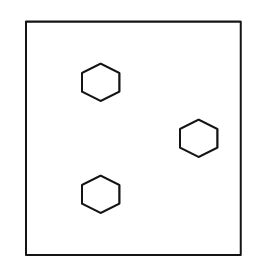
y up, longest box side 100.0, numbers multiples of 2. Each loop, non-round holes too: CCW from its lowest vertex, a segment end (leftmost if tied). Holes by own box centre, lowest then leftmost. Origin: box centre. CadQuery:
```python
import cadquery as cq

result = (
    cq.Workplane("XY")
    .moveTo(-46.0, -50.0)
    .lineTo(46.0, -50.0)
    .lineTo(46.0, 50.0)
    .lineTo(-46.0, 50.0)
    .close()
    .moveTo(-14.0, -32.0)
    .lineTo(-6.0, -28.0)
    .lineTo(-6.0, -20.0)
    .lineTo(-14.0, -16.0)
    .lineTo(-22.0, -20.0)
    .lineTo(-22.0, -28.0)
    .close()
    .moveTo(28.0, -8.0)
    .lineTo(36.0, -4.0)
    .lineTo(36.0, 4.0)
    .lineTo(28.0, 8.0)
    .lineTo(20.0, 4.0)
    .lineTo(20.0, -4.0)
    .close()
    .moveTo(-14.0, 16.0)
    .lineTo(-6.0, 20.0)
    .lineTo(-6.0, 28.0)
    .lineTo(-14.0, 32.0)
    .lineTo(-22.0, 28.0)
    .lineTo(-22.0, 20.0)
    .close()
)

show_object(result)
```